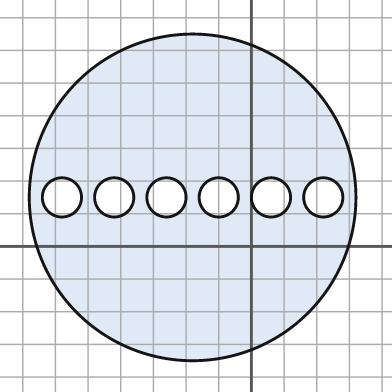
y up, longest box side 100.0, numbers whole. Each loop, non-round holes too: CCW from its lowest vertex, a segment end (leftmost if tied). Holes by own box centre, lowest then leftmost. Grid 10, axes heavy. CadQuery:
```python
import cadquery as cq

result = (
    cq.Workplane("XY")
    .moveTo(-18.0, 15.0)
    .circle(50.0)
    .moveTo(-58.0, 15.0)
    .circle(6.0)
    .moveTo(-42.0, 15.0)
    .circle(6.0)
    .moveTo(-26.0, 15.0)
    .circle(6.0)
    .moveTo(-10.0, 15.0)
    .circle(6.0)
    .moveTo(6.0, 15.0)
    .circle(6.0)
    .moveTo(22.0, 15.0)
    .circle(6.0)
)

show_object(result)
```